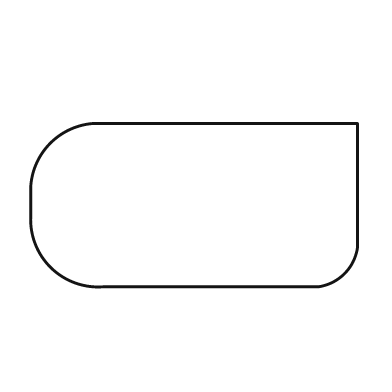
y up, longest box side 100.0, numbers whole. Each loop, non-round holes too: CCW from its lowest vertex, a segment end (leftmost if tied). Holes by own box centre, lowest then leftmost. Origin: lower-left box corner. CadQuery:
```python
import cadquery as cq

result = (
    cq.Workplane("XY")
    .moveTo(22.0, 0.0)
    .lineTo(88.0, 0.0)
    .threePointArc((96.0, 4.0), (100.0, 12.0))
    .lineTo(100.0, 50.0)
    .lineTo(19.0, 50.0)
    .threePointArc((6.0, 44.0), (0.0, 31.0))
    .lineTo(0.0, 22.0)
    .threePointArc((6.0, 6.0), (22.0, 0.0))
    .close()
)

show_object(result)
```